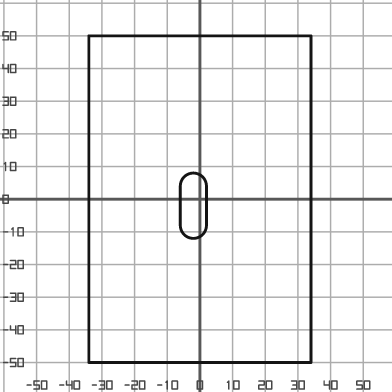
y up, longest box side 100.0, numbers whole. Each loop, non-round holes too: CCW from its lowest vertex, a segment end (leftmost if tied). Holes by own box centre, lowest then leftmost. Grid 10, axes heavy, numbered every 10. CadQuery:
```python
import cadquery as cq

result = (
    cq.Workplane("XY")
    .moveTo(-34.0, -50.0)
    .lineTo(34.0, -50.0)
    .lineTo(34.0, 50.0)
    .lineTo(-34.0, 50.0)
    .close()
    .moveTo(-6.0, -8.0)
    .threePointArc((-2.0, -12.0), (2.0, -8.0))
    .lineTo(2.0, 4.0)
    .threePointArc((-2.0, 8.0), (-6.0, 4.0))
    .close()
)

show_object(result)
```